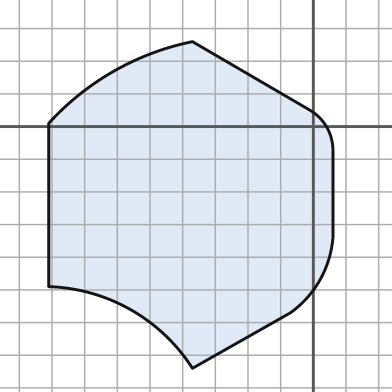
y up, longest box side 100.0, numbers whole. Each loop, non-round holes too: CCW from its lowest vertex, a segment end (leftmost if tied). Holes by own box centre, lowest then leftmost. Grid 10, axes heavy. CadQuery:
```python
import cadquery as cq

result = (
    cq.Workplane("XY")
    .moveTo(-37.0, -74.0)
    .lineTo(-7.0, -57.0)
    .threePointArc((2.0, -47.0), (6.0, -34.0))
    .lineTo(6.0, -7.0)
    .threePointArc((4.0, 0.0), (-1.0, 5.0))
    .lineTo(-37.0, 26.0)
    .threePointArc((-61.0, 17.0), (-81.0, 1.0))
    .lineTo(-81.0, -49.0)
    .threePointArc((-56.0, -56.0), (-37.0, -74.0))
    .close()
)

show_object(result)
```